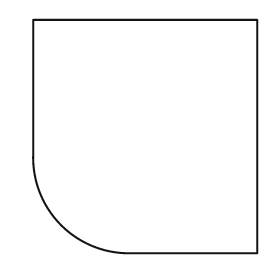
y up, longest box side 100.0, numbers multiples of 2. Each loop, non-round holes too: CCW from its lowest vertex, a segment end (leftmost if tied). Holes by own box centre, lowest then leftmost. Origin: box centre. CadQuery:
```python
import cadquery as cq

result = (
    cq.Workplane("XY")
    .moveTo(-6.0, -50.0)
    .lineTo(48.0, -50.0)
    .lineTo(48.0, 50.0)
    .lineTo(-48.0, 50.0)
    .lineTo(-48.0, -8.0)
    .threePointArc((-36.0, -38.0), (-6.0, -50.0))
    .close()
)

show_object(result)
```